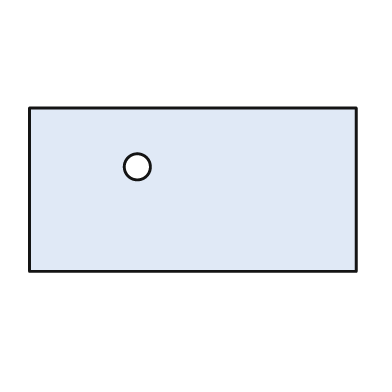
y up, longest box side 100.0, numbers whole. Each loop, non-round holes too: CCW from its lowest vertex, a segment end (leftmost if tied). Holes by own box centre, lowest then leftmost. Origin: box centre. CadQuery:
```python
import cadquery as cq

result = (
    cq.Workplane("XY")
    .moveTo(-50.0, -25.0)
    .lineTo(50.0, -25.0)
    .lineTo(50.0, 25.0)
    .lineTo(-50.0, 25.0)
    .close()
    .moveTo(-17.0, 7.0)
    .circle(4.0)
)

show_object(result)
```